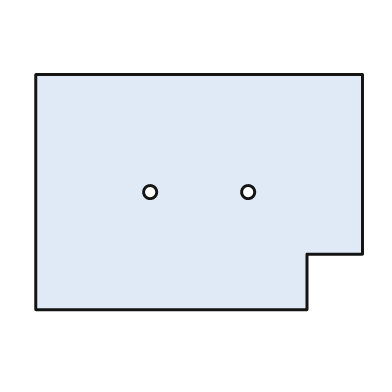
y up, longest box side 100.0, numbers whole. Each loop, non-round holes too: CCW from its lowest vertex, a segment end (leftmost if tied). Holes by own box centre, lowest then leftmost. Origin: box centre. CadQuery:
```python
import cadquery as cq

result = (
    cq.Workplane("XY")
    .moveTo(-50.0, -36.0)
    .lineTo(33.0, -36.0)
    .lineTo(33.0, -19.0)
    .lineTo(50.0, -19.0)
    .lineTo(50.0, 36.0)
    .lineTo(-50.0, 36.0)
    .close()
    .moveTo(-15.0, 0.0)
    .circle(2.0)
    .moveTo(15.0, 0.0)
    .circle(2.0)
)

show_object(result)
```